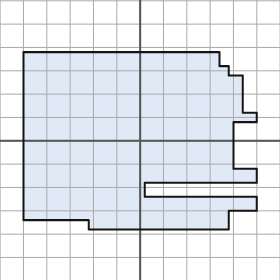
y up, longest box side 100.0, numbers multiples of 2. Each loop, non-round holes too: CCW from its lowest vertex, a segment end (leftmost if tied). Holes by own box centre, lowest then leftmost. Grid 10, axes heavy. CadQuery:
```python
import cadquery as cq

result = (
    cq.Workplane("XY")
    .moveTo(-22.0, -38.0)
    .lineTo(38.0, -38.0)
    .lineTo(38.0, -30.0)
    .lineTo(50.0, -30.0)
    .lineTo(50.0, -24.0)
    .lineTo(2.0, -24.0)
    .lineTo(2.0, -18.0)
    .lineTo(50.0, -18.0)
    .lineTo(50.0, -12.0)
    .lineTo(40.0, -12.0)
    .lineTo(40.0, 8.0)
    .lineTo(50.0, 8.0)
    .lineTo(50.0, 12.0)
    .lineTo(44.0, 12.0)
    .lineTo(44.0, 28.0)
    .lineTo(38.0, 28.0)
    .lineTo(38.0, 32.0)
    .lineTo(34.0, 32.0)
    .lineTo(34.0, 38.0)
    .lineTo(-50.0, 38.0)
    .lineTo(-50.0, -34.0)
    .lineTo(-22.0, -34.0)
    .close()
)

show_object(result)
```